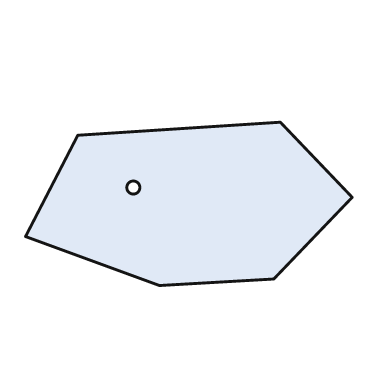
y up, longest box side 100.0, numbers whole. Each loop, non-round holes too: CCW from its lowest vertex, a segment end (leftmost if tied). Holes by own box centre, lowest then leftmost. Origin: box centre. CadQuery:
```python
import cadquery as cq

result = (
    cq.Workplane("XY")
    .moveTo(-9.0, -25.0)
    .lineTo(26.0, -23.0)
    .lineTo(50.0, 2.0)
    .lineTo(28.0, 25.0)
    .lineTo(-34.0, 21.0)
    .lineTo(-50.0, -10.0)
    .close()
    .moveTo(-17.0, 5.0)
    .circle(2.0)
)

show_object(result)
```